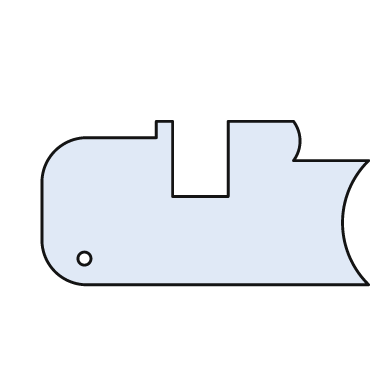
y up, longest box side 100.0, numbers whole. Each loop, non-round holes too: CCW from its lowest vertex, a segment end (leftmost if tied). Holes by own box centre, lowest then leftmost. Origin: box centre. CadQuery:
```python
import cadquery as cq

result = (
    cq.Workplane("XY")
    .moveTo(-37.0, -25.0)
    .lineTo(50.0, -25.0)
    .threePointArc((42.0, -6.0), (50.0, 13.0))
    .lineTo(27.0, 13.0)
    .threePointArc((29.0, 19.0), (27.0, 25.0))
    .lineTo(7.0, 25.0)
    .lineTo(7.0, 2.0)
    .lineTo(-10.0, 2.0)
    .lineTo(-10.0, 25.0)
    .lineTo(-15.0, 25.0)
    .lineTo(-15.0, 20.0)
    .lineTo(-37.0, 20.0)
    .threePointArc((-46.0, 16.0), (-50.0, 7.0))
    .lineTo(-50.0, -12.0)
    .threePointArc((-46.0, -21.0), (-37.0, -25.0))
    .close()
    .moveTo(-37.0, -17.0)
    .circle(2.0)
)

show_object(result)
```